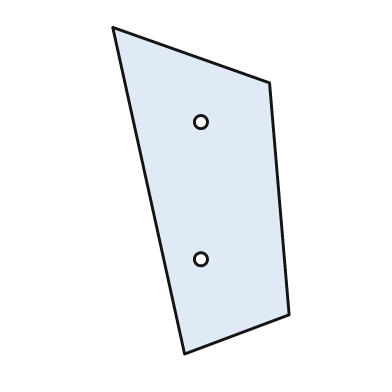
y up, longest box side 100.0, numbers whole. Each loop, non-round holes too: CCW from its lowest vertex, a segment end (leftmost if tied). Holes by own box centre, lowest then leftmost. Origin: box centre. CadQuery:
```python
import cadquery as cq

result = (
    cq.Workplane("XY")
    .moveTo(-5.0, -50.0)
    .lineTo(27.0, -38.0)
    .lineTo(21.0, 33.0)
    .lineTo(-27.0, 50.0)
    .close()
    .moveTo(0.0, -21.0)
    .circle(2.0)
    .moveTo(0.0, 21.0)
    .circle(2.0)
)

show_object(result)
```